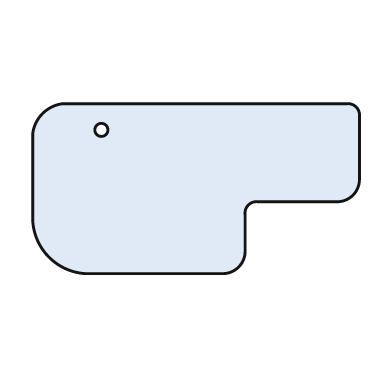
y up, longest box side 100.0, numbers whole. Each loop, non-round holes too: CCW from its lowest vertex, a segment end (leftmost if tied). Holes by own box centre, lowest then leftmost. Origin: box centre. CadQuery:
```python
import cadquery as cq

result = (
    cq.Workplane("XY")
    .moveTo(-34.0, -26.0)
    .lineTo(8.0, -26.0)
    .threePointArc((13.0, -24.0), (15.0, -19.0))
    .lineTo(15.0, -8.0)
    .threePointArc((16.0, -5.0), (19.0, -4.0))
    .lineTo(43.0, -4.0)
    .threePointArc((48.0, -2.0), (50.0, 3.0))
    .lineTo(50.0, 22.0)
    .threePointArc((49.0, 25.0), (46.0, 26.0))
    .lineTo(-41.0, 26.0)
    .threePointArc((-47.0, 23.0), (-50.0, 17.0))
    .lineTo(-50.0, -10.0)
    .threePointArc((-45.0, -21.0), (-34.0, -26.0))
    .close()
    .moveTo(-29.0, 18.0)
    .circle(2.0)
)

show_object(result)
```